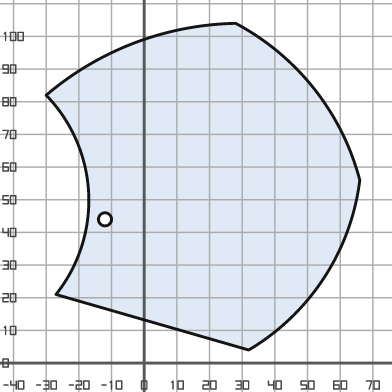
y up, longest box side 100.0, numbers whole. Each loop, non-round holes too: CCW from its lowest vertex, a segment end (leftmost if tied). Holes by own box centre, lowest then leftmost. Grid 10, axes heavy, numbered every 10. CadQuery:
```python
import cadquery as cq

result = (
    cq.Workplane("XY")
    .moveTo(32.0, 4.0)
    .threePointArc((55.0, 26.0), (66.0, 56.0))
    .threePointArc((52.0, 84.0), (28.0, 104.0))
    .threePointArc((-3.0, 98.0), (-30.0, 82.0))
    .threePointArc((-17.0, 52.0), (-27.0, 21.0))
    .close()
    .moveTo(-12.0, 44.0)
    .circle(2.0)
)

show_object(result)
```